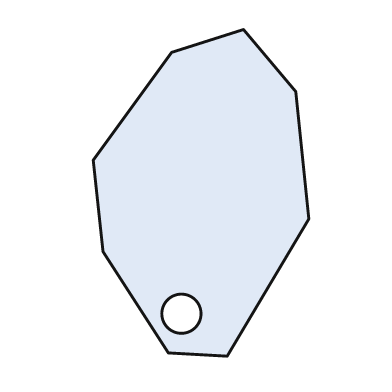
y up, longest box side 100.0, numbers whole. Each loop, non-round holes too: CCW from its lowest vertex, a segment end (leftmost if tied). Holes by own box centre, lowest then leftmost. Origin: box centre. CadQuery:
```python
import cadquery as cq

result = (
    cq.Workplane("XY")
    .moveTo(8.0, -50.0)
    .lineTo(33.0, -8.0)
    .lineTo(29.0, 31.0)
    .lineTo(13.0, 50.0)
    .lineTo(-9.0, 43.0)
    .lineTo(-33.0, 10.0)
    .lineTo(-30.0, -18.0)
    .lineTo(-10.0, -49.0)
    .close()
    .moveTo(-6.0, -37.0)
    .circle(6.0)
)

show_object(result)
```